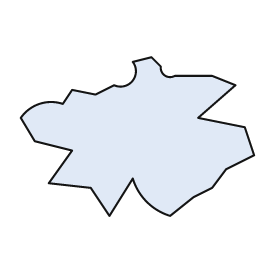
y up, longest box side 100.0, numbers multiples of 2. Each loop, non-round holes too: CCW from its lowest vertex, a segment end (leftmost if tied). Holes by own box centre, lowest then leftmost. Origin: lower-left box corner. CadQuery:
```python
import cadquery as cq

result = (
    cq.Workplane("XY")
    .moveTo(38.0, 0.0)
    .lineTo(48.0, 16.0)
    .threePointArc((54.0, 6.0), (64.0, 0.0))
    .lineTo(74.0, 8.0)
    .lineTo(82.0, 12.0)
    .lineTo(88.0, 20.0)
    .lineTo(100.0, 26.0)
    .lineTo(96.0, 38.0)
    .lineTo(76.0, 42.0)
    .lineTo(92.0, 56.0)
    .lineTo(82.0, 60.0)
    .lineTo(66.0, 60.0)
    .threePointArc((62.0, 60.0), (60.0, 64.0))
    .lineTo(56.0, 68.0)
    .lineTo(48.0, 66.0)
    .threePointArc((48.0, 58.0), (40.0, 56.0))
    .lineTo(32.0, 52.0)
    .lineTo(22.0, 54.0)
    .lineTo(18.0, 48.0)
    .threePointArc((8.0, 48.0), (0.0, 42.0))
    .lineTo(6.0, 32.0)
    .lineTo(22.0, 28.0)
    .lineTo(12.0, 14.0)
    .lineTo(30.0, 12.0)
    .close()
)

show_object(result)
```